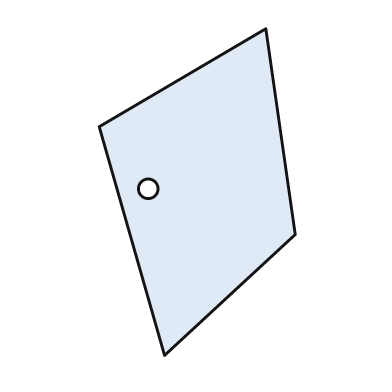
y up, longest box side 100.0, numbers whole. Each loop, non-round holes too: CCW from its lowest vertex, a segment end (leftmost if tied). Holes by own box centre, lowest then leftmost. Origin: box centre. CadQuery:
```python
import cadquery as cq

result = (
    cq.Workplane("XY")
    .moveTo(-10.0, -50.0)
    .lineTo(30.0, -13.0)
    .lineTo(21.0, 50.0)
    .lineTo(-30.0, 20.0)
    .close()
    .moveTo(-15.0, 1.0)
    .circle(3.0)
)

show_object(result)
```